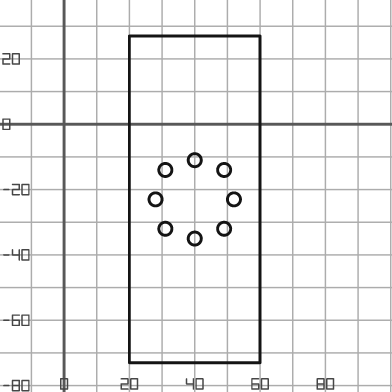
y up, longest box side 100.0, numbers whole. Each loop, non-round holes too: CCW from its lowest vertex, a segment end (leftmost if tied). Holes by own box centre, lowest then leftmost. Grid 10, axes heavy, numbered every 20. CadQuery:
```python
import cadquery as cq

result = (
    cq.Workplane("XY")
    .moveTo(20.0, -73.0)
    .lineTo(60.0, -73.0)
    .lineTo(60.0, 27.0)
    .lineTo(20.0, 27.0)
    .close()
    .moveTo(40.0, -35.0)
    .circle(2.0)
    .moveTo(31.0, -32.0)
    .circle(2.0)
    .moveTo(49.0, -32.0)
    .circle(2.0)
    .moveTo(28.0, -23.0)
    .circle(2.0)
    .moveTo(52.0, -23.0)
    .circle(2.0)
    .moveTo(31.0, -14.0)
    .circle(2.0)
    .moveTo(49.0, -14.0)
    .circle(2.0)
    .moveTo(40.0, -11.0)
    .circle(2.0)
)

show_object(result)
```